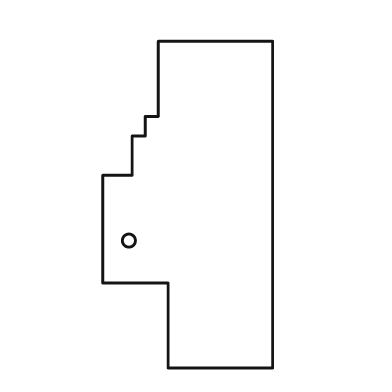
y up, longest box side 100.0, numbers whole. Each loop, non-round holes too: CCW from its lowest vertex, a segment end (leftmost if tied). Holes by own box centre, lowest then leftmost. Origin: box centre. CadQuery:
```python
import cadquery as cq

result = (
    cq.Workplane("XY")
    .moveTo(-6.0, -50.0)
    .lineTo(26.0, -50.0)
    .lineTo(26.0, 50.0)
    .lineTo(-9.0, 50.0)
    .lineTo(-9.0, 27.0)
    .lineTo(-13.0, 27.0)
    .lineTo(-13.0, 21.0)
    .lineTo(-17.0, 21.0)
    .lineTo(-17.0, 9.0)
    .lineTo(-26.0, 9.0)
    .lineTo(-26.0, -24.0)
    .lineTo(-6.0, -24.0)
    .close()
    .moveTo(-18.0, -11.0)
    .circle(2.0)
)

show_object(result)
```